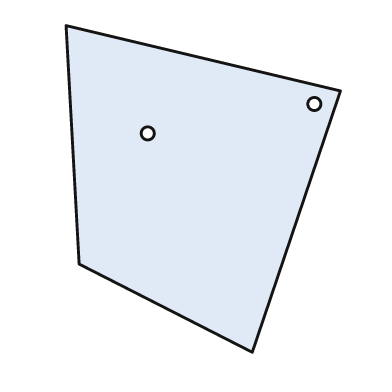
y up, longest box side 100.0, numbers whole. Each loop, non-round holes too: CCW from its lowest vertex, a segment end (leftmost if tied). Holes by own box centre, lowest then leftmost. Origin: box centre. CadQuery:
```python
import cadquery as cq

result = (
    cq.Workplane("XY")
    .moveTo(15.0, -50.0)
    .lineTo(42.0, 30.0)
    .lineTo(-42.0, 50.0)
    .lineTo(-38.0, -23.0)
    .close()
    .moveTo(-17.0, 17.0)
    .circle(2.0)
    .moveTo(34.0, 26.0)
    .circle(2.0)
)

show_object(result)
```